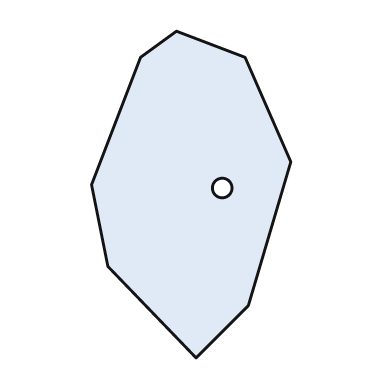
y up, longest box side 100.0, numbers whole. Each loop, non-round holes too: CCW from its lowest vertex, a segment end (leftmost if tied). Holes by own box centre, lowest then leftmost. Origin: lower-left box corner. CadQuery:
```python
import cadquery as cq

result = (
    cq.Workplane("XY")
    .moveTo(32.0, 0.0)
    .lineTo(48.0, 16.0)
    .lineTo(61.0, 60.0)
    .lineTo(47.0, 92.0)
    .lineTo(26.0, 100.0)
    .lineTo(15.0, 92.0)
    .lineTo(0.0, 53.0)
    .lineTo(5.0, 28.0)
    .close()
    .moveTo(40.0, 52.0)
    .circle(3.0)
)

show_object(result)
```